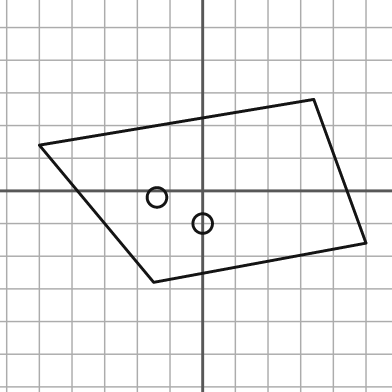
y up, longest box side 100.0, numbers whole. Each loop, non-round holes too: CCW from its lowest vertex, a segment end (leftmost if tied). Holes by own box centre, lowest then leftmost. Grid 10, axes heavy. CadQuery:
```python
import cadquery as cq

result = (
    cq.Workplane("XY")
    .moveTo(-15.0, -28.0)
    .lineTo(50.0, -16.0)
    .lineTo(34.0, 28.0)
    .lineTo(-50.0, 14.0)
    .close()
    .moveTo(0.0, -10.0)
    .circle(3.0)
    .moveTo(-14.0, -2.0)
    .circle(3.0)
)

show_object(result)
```